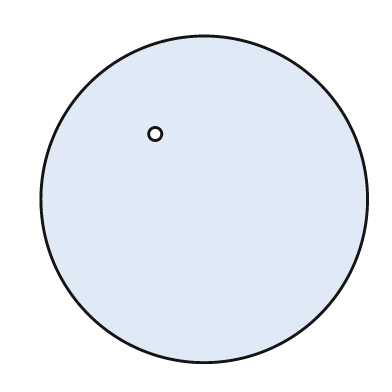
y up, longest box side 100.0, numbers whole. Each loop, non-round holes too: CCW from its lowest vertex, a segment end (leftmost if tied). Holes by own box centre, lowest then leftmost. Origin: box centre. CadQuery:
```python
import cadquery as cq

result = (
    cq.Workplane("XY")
    .moveTo(0.0, 0.0)
    .circle(50.0)
    .moveTo(-15.0, 20.0)
    .circle(2.0)
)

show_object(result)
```